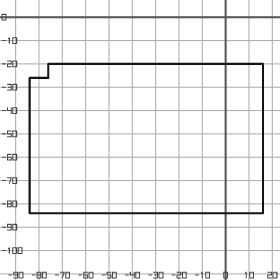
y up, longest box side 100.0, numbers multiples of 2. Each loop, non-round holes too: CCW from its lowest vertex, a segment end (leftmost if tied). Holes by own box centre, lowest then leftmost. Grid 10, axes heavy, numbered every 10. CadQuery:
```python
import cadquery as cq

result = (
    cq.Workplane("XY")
    .moveTo(-84.0, -84.0)
    .lineTo(16.0, -84.0)
    .lineTo(16.0, -20.0)
    .lineTo(-76.0, -20.0)
    .lineTo(-76.0, -26.0)
    .lineTo(-84.0, -26.0)
    .close()
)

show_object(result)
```